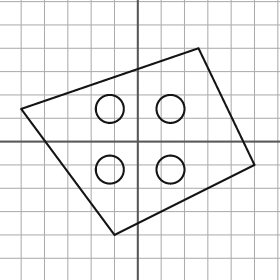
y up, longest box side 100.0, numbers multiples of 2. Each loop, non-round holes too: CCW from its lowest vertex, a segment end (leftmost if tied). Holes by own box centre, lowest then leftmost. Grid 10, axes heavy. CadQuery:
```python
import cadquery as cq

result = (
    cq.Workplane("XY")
    .moveTo(-10.0, -40.0)
    .lineTo(50.0, -10.0)
    .lineTo(26.0, 40.0)
    .lineTo(-50.0, 14.0)
    .close()
    .moveTo(-12.0, -12.0)
    .circle(6.0)
    .moveTo(14.0, -12.0)
    .circle(6.0)
    .moveTo(-12.0, 14.0)
    .circle(6.0)
    .moveTo(14.0, 14.0)
    .circle(6.0)
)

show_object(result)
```